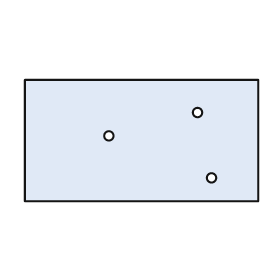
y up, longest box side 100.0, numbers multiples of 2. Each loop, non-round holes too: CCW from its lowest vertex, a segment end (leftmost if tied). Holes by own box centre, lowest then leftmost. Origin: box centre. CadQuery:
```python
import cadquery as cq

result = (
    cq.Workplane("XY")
    .moveTo(-50.0, -26.0)
    .lineTo(50.0, -26.0)
    .lineTo(50.0, 26.0)
    .lineTo(-50.0, 26.0)
    .close()
    .moveTo(30.0, -16.0)
    .circle(2.0)
    .moveTo(-14.0, 2.0)
    .circle(2.0)
    .moveTo(24.0, 12.0)
    .circle(2.0)
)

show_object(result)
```